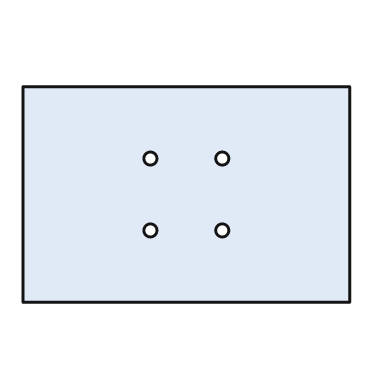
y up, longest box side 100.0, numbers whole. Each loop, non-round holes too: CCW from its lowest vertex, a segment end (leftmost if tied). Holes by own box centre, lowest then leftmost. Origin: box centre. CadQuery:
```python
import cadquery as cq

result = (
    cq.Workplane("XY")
    .moveTo(-50.0, -33.0)
    .lineTo(50.0, -33.0)
    .lineTo(50.0, 33.0)
    .lineTo(-50.0, 33.0)
    .close()
    .moveTo(-11.0, -11.0)
    .circle(2.0)
    .moveTo(11.0, -11.0)
    .circle(2.0)
    .moveTo(-11.0, 11.0)
    .circle(2.0)
    .moveTo(11.0, 11.0)
    .circle(2.0)
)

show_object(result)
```